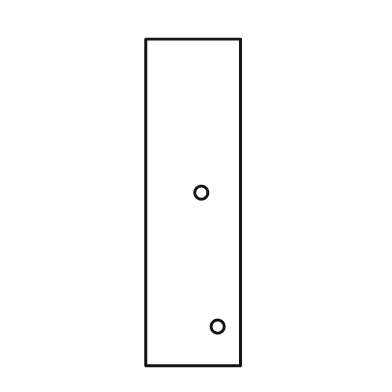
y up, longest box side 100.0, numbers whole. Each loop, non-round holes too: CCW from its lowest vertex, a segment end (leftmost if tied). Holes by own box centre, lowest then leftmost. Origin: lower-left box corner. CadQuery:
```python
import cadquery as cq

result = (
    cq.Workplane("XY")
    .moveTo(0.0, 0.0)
    .lineTo(29.0, 0.0)
    .lineTo(29.0, 100.0)
    .lineTo(0.0, 100.0)
    .close()
    .moveTo(22.0, 12.0)
    .circle(2.0)
    .moveTo(17.0, 53.0)
    .circle(2.0)
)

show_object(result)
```